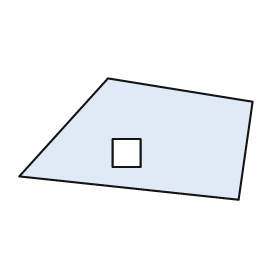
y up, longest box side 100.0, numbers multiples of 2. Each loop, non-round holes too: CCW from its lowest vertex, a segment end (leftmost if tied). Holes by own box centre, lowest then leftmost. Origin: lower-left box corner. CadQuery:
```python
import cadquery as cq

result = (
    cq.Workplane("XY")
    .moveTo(94.0, 0.0)
    .lineTo(100.0, 42.0)
    .lineTo(38.0, 52.0)
    .lineTo(0.0, 10.0)
    .close()
    .moveTo(40.0, 14.0)
    .lineTo(52.0, 14.0)
    .lineTo(52.0, 26.0)
    .lineTo(40.0, 26.0)
    .close()
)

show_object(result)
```